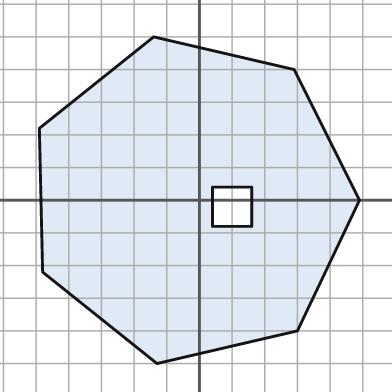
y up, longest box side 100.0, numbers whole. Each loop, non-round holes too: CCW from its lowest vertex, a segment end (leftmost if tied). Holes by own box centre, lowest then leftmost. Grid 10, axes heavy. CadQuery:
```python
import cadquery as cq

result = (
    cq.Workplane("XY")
    .moveTo(-13.0, -50.0)
    .lineTo(30.0, -40.0)
    .lineTo(49.0, 0.0)
    .lineTo(29.0, 40.0)
    .lineTo(-14.0, 50.0)
    .lineTo(-49.0, 22.0)
    .lineTo(-48.0, -22.0)
    .close()
    .moveTo(4.0, -8.0)
    .lineTo(16.0, -8.0)
    .lineTo(16.0, 4.0)
    .lineTo(4.0, 4.0)
    .close()
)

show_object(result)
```